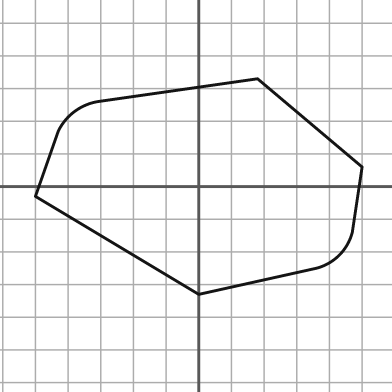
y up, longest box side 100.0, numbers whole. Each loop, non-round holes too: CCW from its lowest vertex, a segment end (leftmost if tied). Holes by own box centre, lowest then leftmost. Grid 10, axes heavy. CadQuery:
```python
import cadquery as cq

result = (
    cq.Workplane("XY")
    .moveTo(0.0, -33.0)
    .lineTo(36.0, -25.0)
    .threePointArc((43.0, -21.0), (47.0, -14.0))
    .lineTo(50.0, 6.0)
    .lineTo(18.0, 33.0)
    .lineTo(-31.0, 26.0)
    .threePointArc((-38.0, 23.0), (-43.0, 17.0))
    .lineTo(-50.0, -3.0)
    .close()
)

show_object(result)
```